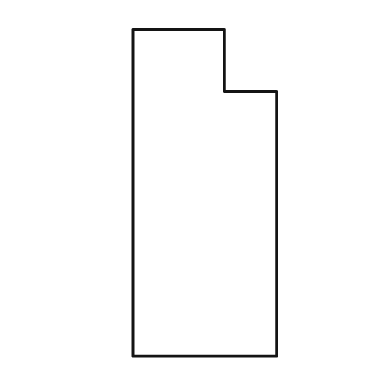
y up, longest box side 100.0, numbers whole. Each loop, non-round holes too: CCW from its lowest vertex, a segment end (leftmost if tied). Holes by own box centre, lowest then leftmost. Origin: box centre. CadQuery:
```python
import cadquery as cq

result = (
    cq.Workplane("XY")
    .moveTo(-22.0, -50.0)
    .lineTo(22.0, -50.0)
    .lineTo(22.0, 31.0)
    .lineTo(6.0, 31.0)
    .lineTo(6.0, 50.0)
    .lineTo(-22.0, 50.0)
    .close()
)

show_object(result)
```